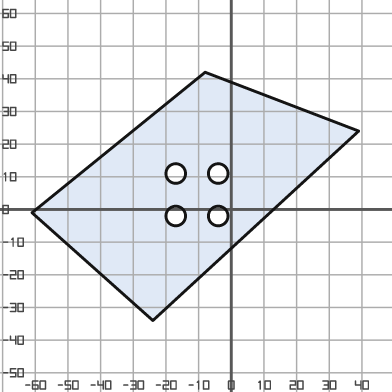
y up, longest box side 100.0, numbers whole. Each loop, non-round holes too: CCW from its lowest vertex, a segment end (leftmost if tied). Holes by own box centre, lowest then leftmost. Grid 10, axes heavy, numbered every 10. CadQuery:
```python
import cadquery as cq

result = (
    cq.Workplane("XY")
    .moveTo(-24.0, -34.0)
    .lineTo(39.0, 24.0)
    .lineTo(-8.0, 42.0)
    .lineTo(-61.0, -1.0)
    .close()
    .moveTo(-17.0, -2.0)
    .circle(3.0)
    .moveTo(-4.0, -2.0)
    .circle(3.0)
    .moveTo(-17.0, 11.0)
    .circle(3.0)
    .moveTo(-4.0, 11.0)
    .circle(3.0)
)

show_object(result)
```